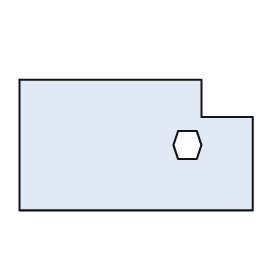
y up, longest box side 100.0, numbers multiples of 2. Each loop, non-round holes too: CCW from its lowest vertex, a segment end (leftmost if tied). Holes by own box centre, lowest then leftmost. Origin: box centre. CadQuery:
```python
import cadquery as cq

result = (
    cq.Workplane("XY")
    .moveTo(-50.0, -28.0)
    .lineTo(50.0, -28.0)
    .lineTo(50.0, 12.0)
    .lineTo(28.0, 12.0)
    .lineTo(28.0, 28.0)
    .lineTo(-50.0, 28.0)
    .close()
    .moveTo(18.0, -6.0)
    .lineTo(26.0, -6.0)
    .lineTo(28.0, 0.0)
    .lineTo(26.0, 6.0)
    .lineTo(18.0, 6.0)
    .lineTo(16.0, 0.0)
    .close()
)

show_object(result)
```